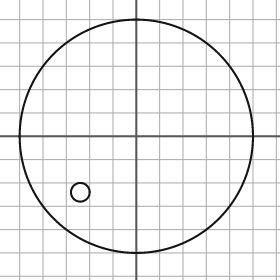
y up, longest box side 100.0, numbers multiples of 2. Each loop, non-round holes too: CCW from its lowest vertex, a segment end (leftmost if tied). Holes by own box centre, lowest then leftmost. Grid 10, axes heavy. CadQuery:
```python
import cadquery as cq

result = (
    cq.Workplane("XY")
    .moveTo(0.0, 0.0)
    .circle(50.0)
    .moveTo(-24.0, -24.0)
    .circle(4.0)
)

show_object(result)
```